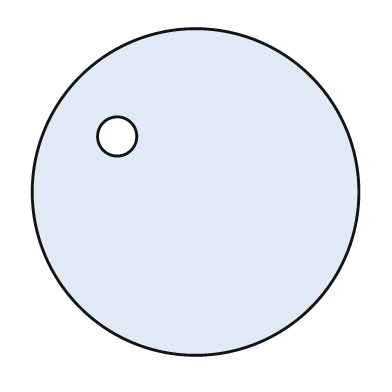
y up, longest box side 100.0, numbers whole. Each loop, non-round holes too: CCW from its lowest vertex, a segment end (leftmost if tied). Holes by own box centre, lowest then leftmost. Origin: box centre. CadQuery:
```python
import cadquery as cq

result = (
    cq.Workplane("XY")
    .moveTo(0.0, 0.0)
    .circle(50.0)
    .moveTo(-24.0, 17.0)
    .circle(6.0)
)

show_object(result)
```